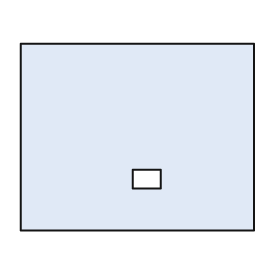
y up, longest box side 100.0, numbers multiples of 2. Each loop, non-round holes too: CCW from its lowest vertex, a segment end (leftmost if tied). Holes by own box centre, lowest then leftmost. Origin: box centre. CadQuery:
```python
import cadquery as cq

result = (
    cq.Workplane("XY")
    .moveTo(-50.0, -40.0)
    .lineTo(50.0, -40.0)
    .lineTo(50.0, 40.0)
    .lineTo(-50.0, 40.0)
    .close()
    .moveTo(-2.0, -22.0)
    .lineTo(10.0, -22.0)
    .lineTo(10.0, -14.0)
    .lineTo(-2.0, -14.0)
    .close()
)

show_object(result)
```